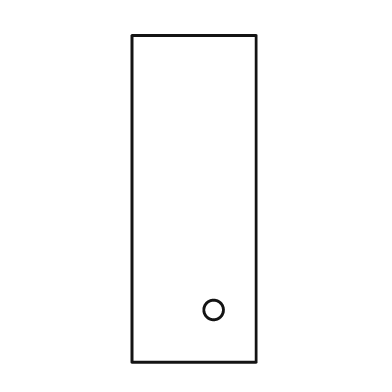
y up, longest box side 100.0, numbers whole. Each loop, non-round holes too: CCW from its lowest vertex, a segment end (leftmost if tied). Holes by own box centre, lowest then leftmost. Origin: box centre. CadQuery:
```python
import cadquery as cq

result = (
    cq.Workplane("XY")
    .moveTo(-19.0, -50.0)
    .lineTo(19.0, -50.0)
    .lineTo(19.0, 50.0)
    .lineTo(-19.0, 50.0)
    .close()
    .moveTo(6.0, -34.0)
    .circle(3.0)
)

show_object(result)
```